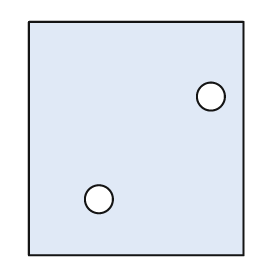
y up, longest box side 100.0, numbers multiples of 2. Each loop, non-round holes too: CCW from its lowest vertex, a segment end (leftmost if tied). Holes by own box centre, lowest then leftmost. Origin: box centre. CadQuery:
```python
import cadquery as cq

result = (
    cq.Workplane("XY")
    .moveTo(-46.0, -50.0)
    .lineTo(46.0, -50.0)
    .lineTo(46.0, 50.0)
    .lineTo(-46.0, 50.0)
    .close()
    .moveTo(-16.0, -26.0)
    .circle(6.0)
    .moveTo(32.0, 18.0)
    .circle(6.0)
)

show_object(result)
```